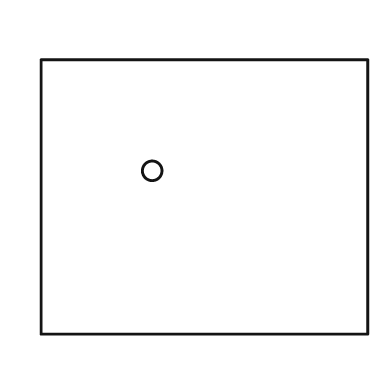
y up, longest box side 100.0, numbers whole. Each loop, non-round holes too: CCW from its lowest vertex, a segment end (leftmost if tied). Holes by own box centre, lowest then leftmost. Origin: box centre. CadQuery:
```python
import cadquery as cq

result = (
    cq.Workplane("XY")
    .moveTo(-50.0, -42.0)
    .lineTo(50.0, -42.0)
    .lineTo(50.0, 42.0)
    .lineTo(-50.0, 42.0)
    .close()
    .moveTo(-16.0, 8.0)
    .circle(3.0)
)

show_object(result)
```